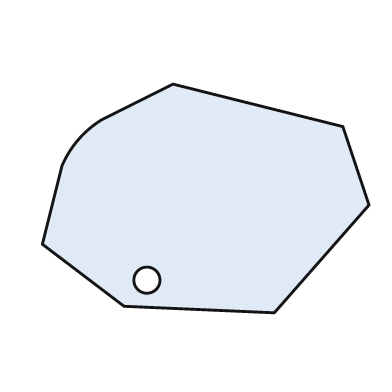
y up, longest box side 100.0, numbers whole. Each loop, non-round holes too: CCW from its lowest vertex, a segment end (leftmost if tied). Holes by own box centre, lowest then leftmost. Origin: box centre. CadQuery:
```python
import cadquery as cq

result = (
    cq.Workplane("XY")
    .moveTo(21.0, -35.0)
    .lineTo(50.0, -2.0)
    .lineTo(42.0, 22.0)
    .lineTo(-10.0, 35.0)
    .lineTo(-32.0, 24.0)
    .threePointArc((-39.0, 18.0), (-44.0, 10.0))
    .lineTo(-50.0, -14.0)
    .lineTo(-25.0, -33.0)
    .close()
    .moveTo(-18.0, -25.0)
    .circle(4.0)
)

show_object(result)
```